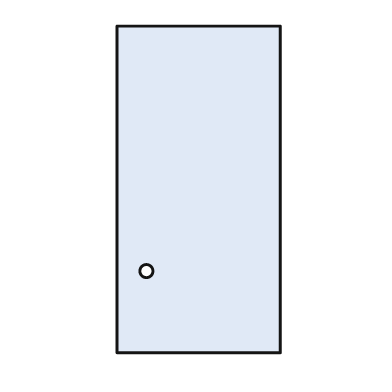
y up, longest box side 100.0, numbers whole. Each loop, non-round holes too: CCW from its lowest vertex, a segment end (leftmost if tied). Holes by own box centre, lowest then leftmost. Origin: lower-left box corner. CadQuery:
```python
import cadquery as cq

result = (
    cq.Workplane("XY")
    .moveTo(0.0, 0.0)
    .lineTo(50.0, 0.0)
    .lineTo(50.0, 100.0)
    .lineTo(0.0, 100.0)
    .close()
    .moveTo(9.0, 25.0)
    .circle(2.0)
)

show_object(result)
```